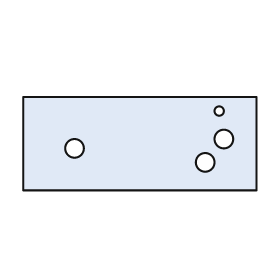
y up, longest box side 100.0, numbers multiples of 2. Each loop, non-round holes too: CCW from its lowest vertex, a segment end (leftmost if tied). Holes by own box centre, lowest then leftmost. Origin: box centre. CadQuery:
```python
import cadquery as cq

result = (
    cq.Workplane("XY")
    .moveTo(-50.0, -20.0)
    .lineTo(50.0, -20.0)
    .lineTo(50.0, 20.0)
    .lineTo(-50.0, 20.0)
    .close()
    .moveTo(28.0, -8.0)
    .circle(4.0)
    .moveTo(-28.0, -2.0)
    .circle(4.0)
    .moveTo(36.0, 2.0)
    .circle(4.0)
    .moveTo(34.0, 14.0)
    .circle(2.0)
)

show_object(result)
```